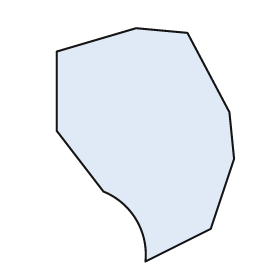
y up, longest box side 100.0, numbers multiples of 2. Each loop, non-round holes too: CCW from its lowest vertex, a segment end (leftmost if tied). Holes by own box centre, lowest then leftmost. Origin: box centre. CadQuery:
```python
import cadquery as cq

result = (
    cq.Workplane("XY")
    .moveTo(0.0, -50.0)
    .lineTo(28.0, -36.0)
    .lineTo(38.0, -6.0)
    .lineTo(36.0, 14.0)
    .lineTo(18.0, 48.0)
    .lineTo(-4.0, 50.0)
    .lineTo(-38.0, 40.0)
    .lineTo(-38.0, 6.0)
    .lineTo(-18.0, -20.0)
    .threePointArc((-4.0, -32.0), (0.0, -50.0))
    .close()
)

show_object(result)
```